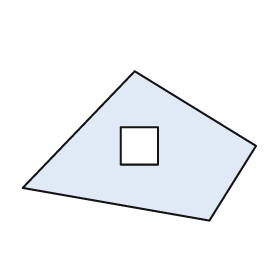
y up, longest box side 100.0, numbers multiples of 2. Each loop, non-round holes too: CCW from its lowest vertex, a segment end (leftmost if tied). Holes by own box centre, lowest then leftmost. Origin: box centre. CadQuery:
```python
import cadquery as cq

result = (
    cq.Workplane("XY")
    .moveTo(30.0, -32.0)
    .lineTo(50.0, 0.0)
    .lineTo(-2.0, 32.0)
    .lineTo(-50.0, -18.0)
    .close()
    .moveTo(-8.0, -8.0)
    .lineTo(8.0, -8.0)
    .lineTo(8.0, 8.0)
    .lineTo(-8.0, 8.0)
    .close()
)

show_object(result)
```